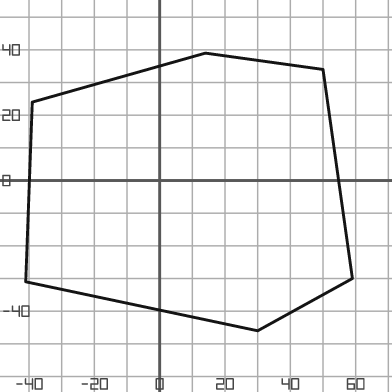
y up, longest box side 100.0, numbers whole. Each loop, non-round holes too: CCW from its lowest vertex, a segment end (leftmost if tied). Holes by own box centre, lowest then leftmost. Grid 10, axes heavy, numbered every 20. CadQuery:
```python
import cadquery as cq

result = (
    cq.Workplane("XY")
    .moveTo(30.0, -46.0)
    .lineTo(59.0, -30.0)
    .lineTo(50.0, 34.0)
    .lineTo(14.0, 39.0)
    .lineTo(-39.0, 24.0)
    .lineTo(-41.0, -31.0)
    .close()
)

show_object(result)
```